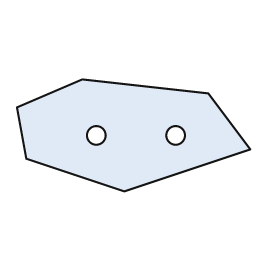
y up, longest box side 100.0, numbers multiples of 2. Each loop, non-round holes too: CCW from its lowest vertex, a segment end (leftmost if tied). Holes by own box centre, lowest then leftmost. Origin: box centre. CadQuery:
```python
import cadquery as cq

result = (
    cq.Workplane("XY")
    .moveTo(-4.0, -24.0)
    .lineTo(50.0, -6.0)
    .lineTo(32.0, 18.0)
    .lineTo(-22.0, 24.0)
    .lineTo(-50.0, 12.0)
    .lineTo(-46.0, -10.0)
    .close()
    .moveTo(-16.0, 0.0)
    .circle(4.0)
    .moveTo(18.0, 0.0)
    .circle(4.0)
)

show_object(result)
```